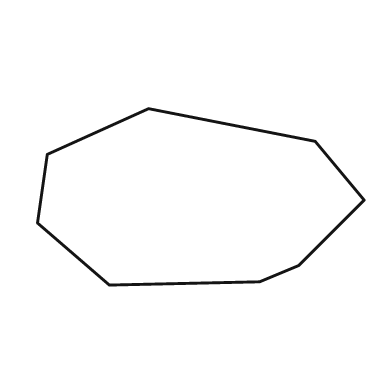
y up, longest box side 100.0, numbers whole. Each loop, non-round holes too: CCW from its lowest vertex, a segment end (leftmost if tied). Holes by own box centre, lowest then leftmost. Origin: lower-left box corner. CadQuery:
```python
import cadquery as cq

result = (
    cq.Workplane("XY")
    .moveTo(22.0, 0.0)
    .lineTo(68.0, 1.0)
    .lineTo(80.0, 6.0)
    .lineTo(100.0, 26.0)
    .lineTo(85.0, 44.0)
    .lineTo(34.0, 54.0)
    .lineTo(3.0, 40.0)
    .lineTo(0.0, 19.0)
    .close()
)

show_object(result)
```